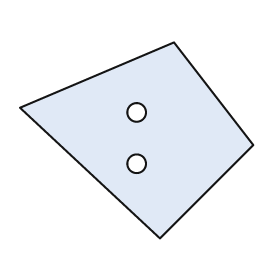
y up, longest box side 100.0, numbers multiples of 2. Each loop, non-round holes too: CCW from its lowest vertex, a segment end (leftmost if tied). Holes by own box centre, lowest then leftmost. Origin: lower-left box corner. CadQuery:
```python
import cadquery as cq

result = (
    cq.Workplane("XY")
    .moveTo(60.0, 0.0)
    .lineTo(100.0, 40.0)
    .lineTo(66.0, 84.0)
    .lineTo(0.0, 56.0)
    .close()
    .moveTo(50.0, 32.0)
    .circle(4.0)
    .moveTo(50.0, 54.0)
    .circle(4.0)
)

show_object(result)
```